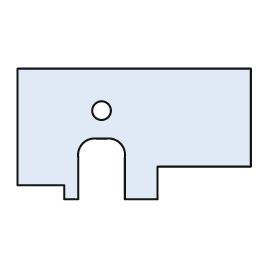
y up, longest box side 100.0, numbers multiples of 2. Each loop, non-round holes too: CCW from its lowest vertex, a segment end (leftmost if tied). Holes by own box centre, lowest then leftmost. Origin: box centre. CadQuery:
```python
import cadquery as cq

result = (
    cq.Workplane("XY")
    .moveTo(-30.0, -28.0)
    .lineTo(-24.0, -28.0)
    .lineTo(-24.0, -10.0)
    .threePointArc((-22.0, -4.0), (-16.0, -2.0))
    .lineTo(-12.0, -2.0)
    .threePointArc((-6.0, -4.0), (-4.0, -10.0))
    .lineTo(-4.0, -28.0)
    .lineTo(10.0, -28.0)
    .lineTo(10.0, -14.0)
    .lineTo(50.0, -14.0)
    .lineTo(50.0, 28.0)
    .lineTo(-50.0, 28.0)
    .lineTo(-50.0, -22.0)
    .lineTo(-30.0, -22.0)
    .close()
    .moveTo(-14.0, 10.0)
    .circle(4.0)
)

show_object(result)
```